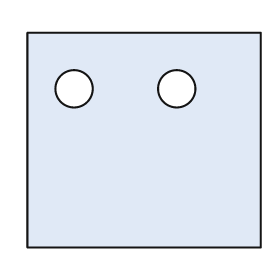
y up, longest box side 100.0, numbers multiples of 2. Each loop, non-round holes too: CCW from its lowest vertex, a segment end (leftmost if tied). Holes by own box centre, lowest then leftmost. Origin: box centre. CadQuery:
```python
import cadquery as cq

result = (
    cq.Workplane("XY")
    .moveTo(-50.0, -46.0)
    .lineTo(50.0, -46.0)
    .lineTo(50.0, 46.0)
    .lineTo(-50.0, 46.0)
    .close()
    .moveTo(-30.0, 22.0)
    .circle(8.0)
    .moveTo(14.0, 22.0)
    .circle(8.0)
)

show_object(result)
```